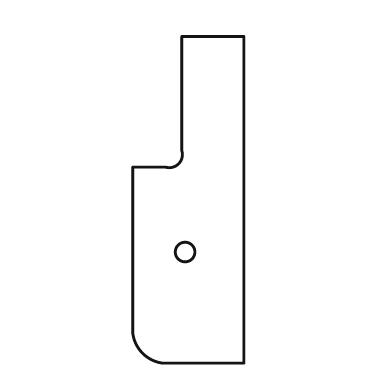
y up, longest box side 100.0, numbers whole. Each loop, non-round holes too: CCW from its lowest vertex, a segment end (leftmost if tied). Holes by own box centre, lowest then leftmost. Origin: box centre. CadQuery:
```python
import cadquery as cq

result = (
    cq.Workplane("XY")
    .moveTo(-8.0, -50.0)
    .lineTo(17.0, -50.0)
    .lineTo(17.0, 50.0)
    .lineTo(-2.0, 50.0)
    .lineTo(-2.0, 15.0)
    .threePointArc((-3.0, 11.0), (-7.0, 10.0))
    .lineTo(-17.0, 10.0)
    .lineTo(-17.0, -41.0)
    .threePointArc((-14.0, -47.0), (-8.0, -50.0))
    .close()
    .moveTo(-1.0, -16.0)
    .circle(3.0)
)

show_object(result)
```